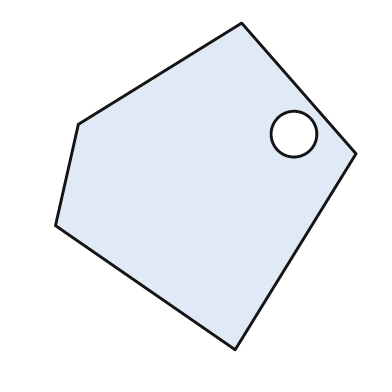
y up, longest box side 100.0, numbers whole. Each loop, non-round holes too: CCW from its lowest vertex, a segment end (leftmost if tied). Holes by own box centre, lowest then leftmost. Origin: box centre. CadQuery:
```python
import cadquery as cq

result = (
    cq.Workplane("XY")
    .moveTo(9.0, -50.0)
    .lineTo(46.0, 10.0)
    .lineTo(11.0, 50.0)
    .lineTo(-39.0, 19.0)
    .lineTo(-46.0, -12.0)
    .close()
    .moveTo(27.0, 16.0)
    .circle(7.0)
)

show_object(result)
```